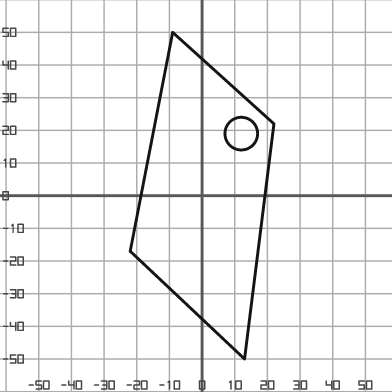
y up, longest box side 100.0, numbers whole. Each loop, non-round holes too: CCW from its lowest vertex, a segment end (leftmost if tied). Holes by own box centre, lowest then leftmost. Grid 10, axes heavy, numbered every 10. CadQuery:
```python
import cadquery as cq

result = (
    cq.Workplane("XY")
    .moveTo(13.0, -50.0)
    .lineTo(22.0, 22.0)
    .lineTo(-9.0, 50.0)
    .lineTo(-22.0, -17.0)
    .close()
    .moveTo(12.0, 19.0)
    .circle(5.0)
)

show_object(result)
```